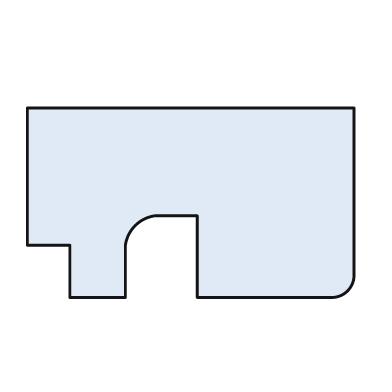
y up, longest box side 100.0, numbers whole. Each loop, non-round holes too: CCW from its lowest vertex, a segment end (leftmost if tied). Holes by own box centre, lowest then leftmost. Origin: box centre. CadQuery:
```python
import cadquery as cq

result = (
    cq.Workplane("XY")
    .moveTo(-37.0, -29.0)
    .lineTo(-20.0, -29.0)
    .lineTo(-20.0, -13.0)
    .threePointArc((-17.0, -7.0), (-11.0, -4.0))
    .lineTo(2.0, -4.0)
    .lineTo(2.0, -29.0)
    .lineTo(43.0, -29.0)
    .threePointArc((48.0, -27.0), (50.0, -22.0))
    .lineTo(50.0, 29.0)
    .lineTo(-50.0, 29.0)
    .lineTo(-50.0, -13.0)
    .lineTo(-37.0, -13.0)
    .close()
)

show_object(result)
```